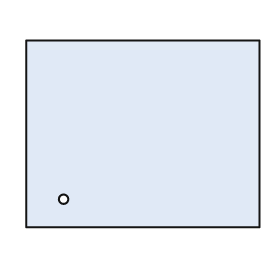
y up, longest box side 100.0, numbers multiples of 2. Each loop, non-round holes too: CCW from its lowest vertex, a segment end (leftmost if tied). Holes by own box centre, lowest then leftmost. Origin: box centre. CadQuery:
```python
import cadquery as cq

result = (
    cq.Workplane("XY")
    .moveTo(-50.0, -40.0)
    .lineTo(50.0, -40.0)
    .lineTo(50.0, 40.0)
    .lineTo(-50.0, 40.0)
    .close()
    .moveTo(-34.0, -28.0)
    .circle(2.0)
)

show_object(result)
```